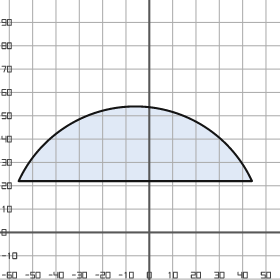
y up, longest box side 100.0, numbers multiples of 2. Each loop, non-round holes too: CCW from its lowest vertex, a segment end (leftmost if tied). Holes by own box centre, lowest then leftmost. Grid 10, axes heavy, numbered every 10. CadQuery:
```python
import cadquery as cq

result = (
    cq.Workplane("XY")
    .moveTo(-56.0, 22.0)
    .lineTo(44.0, 22.0)
    .threePointArc((-6.0, 54.0), (-56.0, 22.0))
    .close()
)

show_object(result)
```